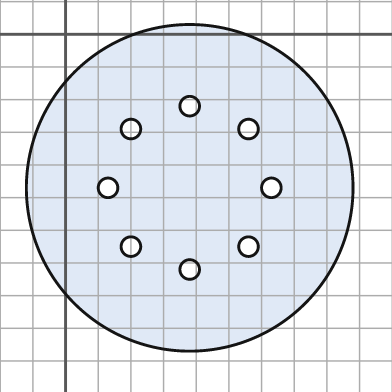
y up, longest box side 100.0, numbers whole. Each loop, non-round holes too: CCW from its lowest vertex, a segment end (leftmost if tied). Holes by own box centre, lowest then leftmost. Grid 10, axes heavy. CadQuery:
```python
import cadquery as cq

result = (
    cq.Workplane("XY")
    .moveTo(38.0, -47.0)
    .circle(50.0)
    .moveTo(38.0, -72.0)
    .circle(3.0)
    .moveTo(20.0, -65.0)
    .circle(3.0)
    .moveTo(56.0, -65.0)
    .circle(3.0)
    .moveTo(13.0, -47.0)
    .circle(3.0)
    .moveTo(63.0, -47.0)
    .circle(3.0)
    .moveTo(20.0, -29.0)
    .circle(3.0)
    .moveTo(56.0, -29.0)
    .circle(3.0)
    .moveTo(38.0, -22.0)
    .circle(3.0)
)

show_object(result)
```